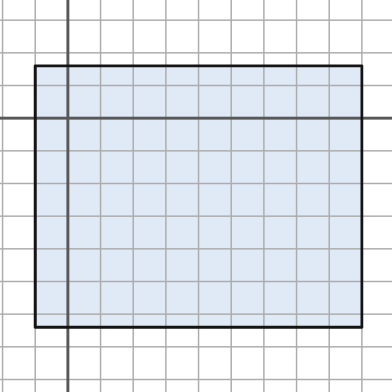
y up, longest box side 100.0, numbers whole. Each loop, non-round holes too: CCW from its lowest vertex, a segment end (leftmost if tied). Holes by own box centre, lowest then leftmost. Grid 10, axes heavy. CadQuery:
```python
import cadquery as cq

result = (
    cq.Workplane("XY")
    .moveTo(-10.0, -64.0)
    .lineTo(90.0, -64.0)
    .lineTo(90.0, 16.0)
    .lineTo(-10.0, 16.0)
    .close()
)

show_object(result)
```